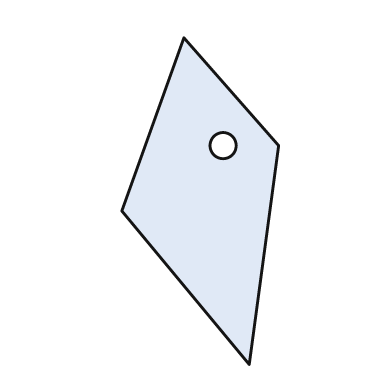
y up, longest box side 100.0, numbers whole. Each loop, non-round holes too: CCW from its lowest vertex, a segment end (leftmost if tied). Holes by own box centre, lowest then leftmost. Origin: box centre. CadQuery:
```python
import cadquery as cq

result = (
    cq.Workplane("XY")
    .moveTo(15.0, -50.0)
    .lineTo(24.0, 17.0)
    .lineTo(-5.0, 50.0)
    .lineTo(-24.0, -3.0)
    .close()
    .moveTo(7.0, 17.0)
    .circle(4.0)
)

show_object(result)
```